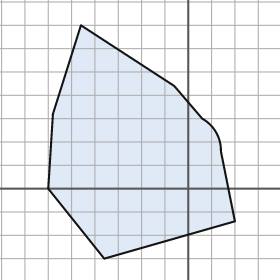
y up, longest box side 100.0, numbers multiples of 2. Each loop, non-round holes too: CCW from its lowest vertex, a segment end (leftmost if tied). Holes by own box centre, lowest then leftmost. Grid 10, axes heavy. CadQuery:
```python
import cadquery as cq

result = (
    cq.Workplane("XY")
    .moveTo(-36.0, -30.0)
    .lineTo(20.0, -14.0)
    .lineTo(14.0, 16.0)
    .threePointArc((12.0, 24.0), (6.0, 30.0))
    .lineTo(-6.0, 44.0)
    .lineTo(-46.0, 70.0)
    .lineTo(-58.0, 32.0)
    .lineTo(-60.0, 0.0)
    .close()
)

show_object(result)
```